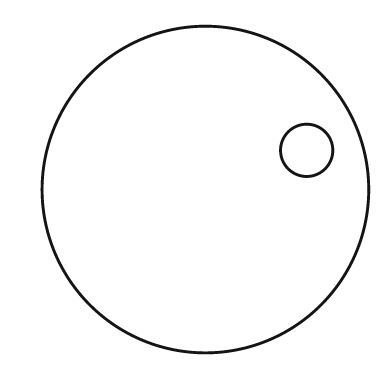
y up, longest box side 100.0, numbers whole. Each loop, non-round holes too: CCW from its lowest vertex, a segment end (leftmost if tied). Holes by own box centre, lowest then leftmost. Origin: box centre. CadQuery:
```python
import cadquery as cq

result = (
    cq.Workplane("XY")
    .moveTo(0.0, 0.0)
    .circle(50.0)
    .moveTo(31.0, 12.0)
    .circle(8.0)
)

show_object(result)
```